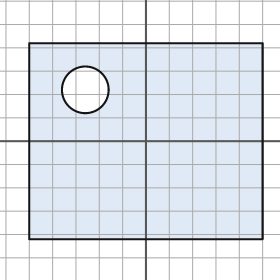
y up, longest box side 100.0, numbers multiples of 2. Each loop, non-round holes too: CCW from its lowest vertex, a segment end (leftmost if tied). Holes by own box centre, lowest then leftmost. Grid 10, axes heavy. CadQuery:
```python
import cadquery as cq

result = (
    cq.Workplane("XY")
    .moveTo(-50.0, -42.0)
    .lineTo(50.0, -42.0)
    .lineTo(50.0, 42.0)
    .lineTo(-50.0, 42.0)
    .close()
    .moveTo(-26.0, 22.0)
    .circle(10.0)
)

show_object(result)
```